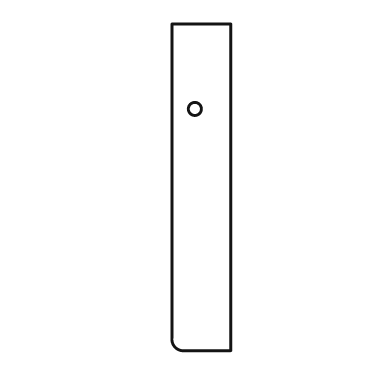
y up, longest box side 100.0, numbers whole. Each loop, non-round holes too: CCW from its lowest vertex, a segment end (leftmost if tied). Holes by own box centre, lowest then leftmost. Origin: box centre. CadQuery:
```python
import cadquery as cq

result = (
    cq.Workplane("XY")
    .moveTo(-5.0, -50.0)
    .lineTo(9.0, -50.0)
    .lineTo(9.0, 50.0)
    .lineTo(-9.0, 50.0)
    .lineTo(-9.0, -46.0)
    .threePointArc((-8.0, -49.0), (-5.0, -50.0))
    .close()
    .moveTo(-2.0, 24.0)
    .circle(2.0)
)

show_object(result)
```